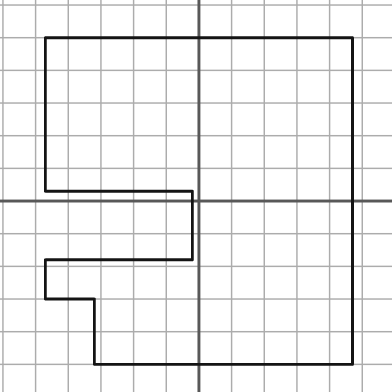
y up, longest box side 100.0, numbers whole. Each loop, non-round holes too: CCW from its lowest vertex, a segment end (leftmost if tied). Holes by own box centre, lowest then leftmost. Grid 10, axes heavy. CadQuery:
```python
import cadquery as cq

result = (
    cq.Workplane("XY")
    .moveTo(-32.0, -50.0)
    .lineTo(47.0, -50.0)
    .lineTo(47.0, 50.0)
    .lineTo(-47.0, 50.0)
    .lineTo(-47.0, 3.0)
    .lineTo(-2.0, 3.0)
    .lineTo(-2.0, -18.0)
    .lineTo(-47.0, -18.0)
    .lineTo(-47.0, -30.0)
    .lineTo(-32.0, -30.0)
    .close()
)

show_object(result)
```